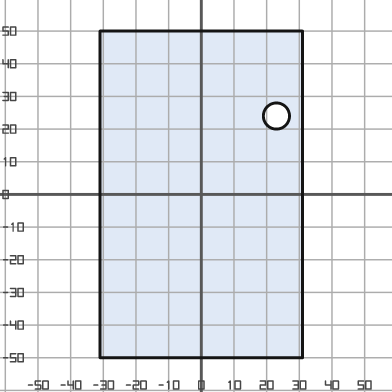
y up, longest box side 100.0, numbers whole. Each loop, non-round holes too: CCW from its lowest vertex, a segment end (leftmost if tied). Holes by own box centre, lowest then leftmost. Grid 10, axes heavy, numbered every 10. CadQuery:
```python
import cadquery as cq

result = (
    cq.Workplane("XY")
    .moveTo(-31.0, -50.0)
    .lineTo(31.0, -50.0)
    .lineTo(31.0, 50.0)
    .lineTo(-31.0, 50.0)
    .close()
    .moveTo(23.0, 24.0)
    .circle(4.0)
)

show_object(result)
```